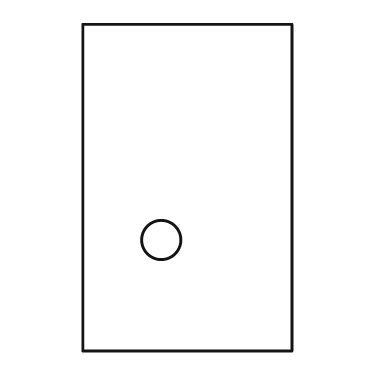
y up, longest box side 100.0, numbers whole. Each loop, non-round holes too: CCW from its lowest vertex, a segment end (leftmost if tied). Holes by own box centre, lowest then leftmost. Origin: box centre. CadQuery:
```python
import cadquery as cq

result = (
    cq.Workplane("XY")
    .moveTo(-32.0, -50.0)
    .lineTo(32.0, -50.0)
    .lineTo(32.0, 50.0)
    .lineTo(-32.0, 50.0)
    .close()
    .moveTo(-8.0, -16.0)
    .circle(6.0)
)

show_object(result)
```